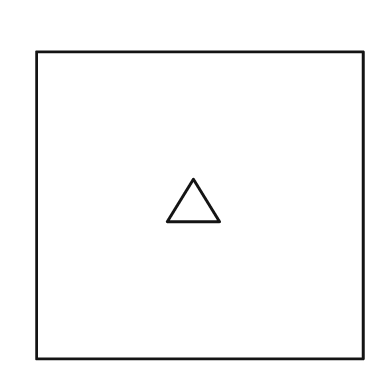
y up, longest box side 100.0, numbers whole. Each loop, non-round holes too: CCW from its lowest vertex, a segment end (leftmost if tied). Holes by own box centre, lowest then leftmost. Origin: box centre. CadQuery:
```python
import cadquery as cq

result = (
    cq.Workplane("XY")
    .moveTo(-50.0, -47.0)
    .lineTo(50.0, -47.0)
    .lineTo(50.0, 47.0)
    .lineTo(-50.0, 47.0)
    .close()
    .moveTo(-10.0, -5.0)
    .lineTo(6.0, -5.0)
    .lineTo(-2.0, 8.0)
    .close()
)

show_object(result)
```